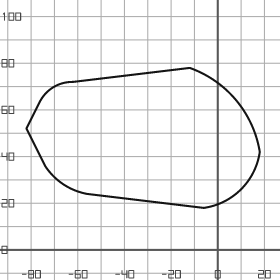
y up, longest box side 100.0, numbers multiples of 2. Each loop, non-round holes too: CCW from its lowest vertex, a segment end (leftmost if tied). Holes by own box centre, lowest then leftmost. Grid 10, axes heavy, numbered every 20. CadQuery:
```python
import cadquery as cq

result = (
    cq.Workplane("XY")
    .moveTo(-6.0, 18.0)
    .threePointArc((10.0, 26.0), (18.0, 42.0))
    .threePointArc((8.0, 64.0), (-12.0, 78.0))
    .lineTo(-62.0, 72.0)
    .threePointArc((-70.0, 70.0), (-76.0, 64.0))
    .lineTo(-82.0, 52.0)
    .lineTo(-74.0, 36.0)
    .threePointArc((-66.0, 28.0), (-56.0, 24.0))
    .close()
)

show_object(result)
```